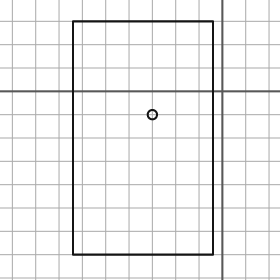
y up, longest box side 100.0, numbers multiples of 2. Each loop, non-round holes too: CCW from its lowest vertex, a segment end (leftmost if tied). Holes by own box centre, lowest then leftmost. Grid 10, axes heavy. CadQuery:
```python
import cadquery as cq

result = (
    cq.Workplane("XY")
    .moveTo(-64.0, -70.0)
    .lineTo(-4.0, -70.0)
    .lineTo(-4.0, 30.0)
    .lineTo(-64.0, 30.0)
    .close()
    .moveTo(-30.0, -10.0)
    .circle(2.0)
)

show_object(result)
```